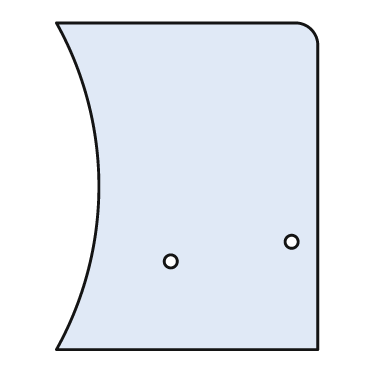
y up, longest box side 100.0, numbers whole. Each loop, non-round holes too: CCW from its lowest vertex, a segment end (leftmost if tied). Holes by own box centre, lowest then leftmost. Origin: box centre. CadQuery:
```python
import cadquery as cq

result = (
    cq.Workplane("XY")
    .moveTo(-40.0, -50.0)
    .lineTo(40.0, -50.0)
    .lineTo(40.0, 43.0)
    .threePointArc((38.0, 48.0), (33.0, 50.0))
    .lineTo(-40.0, 50.0)
    .threePointArc((-27.0, 0.0), (-40.0, -50.0))
    .close()
    .moveTo(-5.0, -23.0)
    .circle(2.0)
    .moveTo(32.0, -17.0)
    .circle(2.0)
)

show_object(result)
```